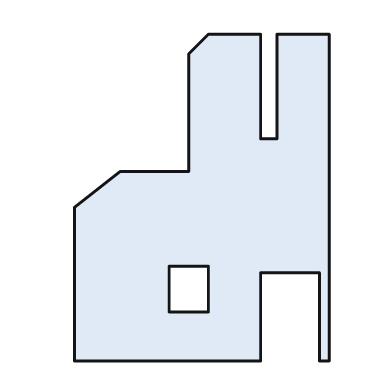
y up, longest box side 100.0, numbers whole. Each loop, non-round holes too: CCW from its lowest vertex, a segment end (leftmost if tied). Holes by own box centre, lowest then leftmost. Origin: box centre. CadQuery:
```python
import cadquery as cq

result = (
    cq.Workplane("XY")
    .moveTo(-39.0, -50.0)
    .lineTo(18.0, -50.0)
    .lineTo(18.0, -23.0)
    .lineTo(36.0, -23.0)
    .lineTo(36.0, -50.0)
    .lineTo(39.0, -50.0)
    .lineTo(39.0, 50.0)
    .lineTo(23.0, 50.0)
    .lineTo(23.0, 18.0)
    .lineTo(18.0, 18.0)
    .lineTo(18.0, 50.0)
    .lineTo(2.0, 50.0)
    .lineTo(-4.0, 44.0)
    .lineTo(-4.0, 8.0)
    .lineTo(-25.0, 8.0)
    .lineTo(-39.0, -3.0)
    .close()
    .moveTo(-10.0, -35.0)
    .lineTo(2.0, -35.0)
    .lineTo(2.0, -21.0)
    .lineTo(-10.0, -21.0)
    .close()
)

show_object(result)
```